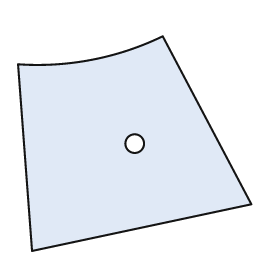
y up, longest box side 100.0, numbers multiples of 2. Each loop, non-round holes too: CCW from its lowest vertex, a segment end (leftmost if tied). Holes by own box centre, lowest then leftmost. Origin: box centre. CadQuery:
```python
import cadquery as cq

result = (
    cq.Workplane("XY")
    .moveTo(-44.0, -46.0)
    .lineTo(50.0, -26.0)
    .lineTo(12.0, 46.0)
    .threePointArc((-18.0, 36.0), (-50.0, 34.0))
    .close()
    .moveTo(0.0, 0.0)
    .circle(4.0)
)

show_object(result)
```